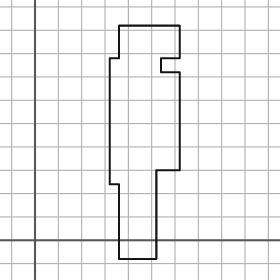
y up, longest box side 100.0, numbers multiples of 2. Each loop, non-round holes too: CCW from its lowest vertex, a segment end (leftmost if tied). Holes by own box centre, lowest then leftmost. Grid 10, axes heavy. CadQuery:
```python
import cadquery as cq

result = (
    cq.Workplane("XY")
    .moveTo(36.0, -8.0)
    .lineTo(52.0, -8.0)
    .lineTo(52.0, 30.0)
    .lineTo(62.0, 30.0)
    .lineTo(62.0, 72.0)
    .lineTo(54.0, 72.0)
    .lineTo(54.0, 78.0)
    .lineTo(62.0, 78.0)
    .lineTo(62.0, 92.0)
    .lineTo(36.0, 92.0)
    .lineTo(36.0, 78.0)
    .lineTo(32.0, 78.0)
    .lineTo(32.0, 24.0)
    .lineTo(36.0, 24.0)
    .close()
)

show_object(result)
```